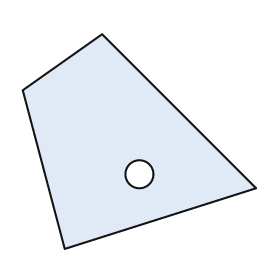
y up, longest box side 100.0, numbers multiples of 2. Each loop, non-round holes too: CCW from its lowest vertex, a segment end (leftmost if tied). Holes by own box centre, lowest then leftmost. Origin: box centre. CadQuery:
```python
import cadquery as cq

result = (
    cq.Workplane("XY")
    .moveTo(-32.0, -46.0)
    .lineTo(50.0, -20.0)
    .lineTo(-16.0, 46.0)
    .lineTo(-50.0, 22.0)
    .close()
    .moveTo(0.0, -14.0)
    .circle(6.0)
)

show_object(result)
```